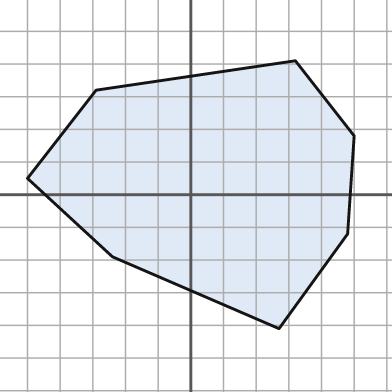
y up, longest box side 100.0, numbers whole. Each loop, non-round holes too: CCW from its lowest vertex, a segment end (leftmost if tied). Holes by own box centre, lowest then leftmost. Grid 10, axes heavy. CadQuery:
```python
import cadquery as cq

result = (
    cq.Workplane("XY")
    .moveTo(27.0, -41.0)
    .lineTo(48.0, -12.0)
    .lineTo(50.0, 18.0)
    .lineTo(32.0, 41.0)
    .lineTo(-29.0, 32.0)
    .lineTo(-50.0, 5.0)
    .lineTo(-24.0, -19.0)
    .close()
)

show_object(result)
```